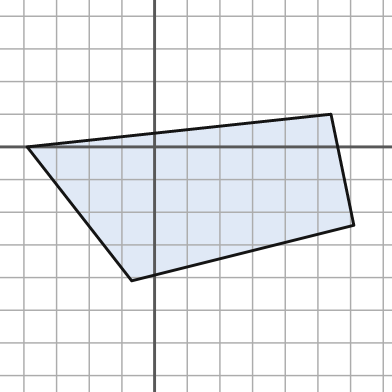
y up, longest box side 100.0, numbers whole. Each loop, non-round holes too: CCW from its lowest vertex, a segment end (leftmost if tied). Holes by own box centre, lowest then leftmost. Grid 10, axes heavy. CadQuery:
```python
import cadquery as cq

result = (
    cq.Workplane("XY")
    .moveTo(-7.0, -41.0)
    .lineTo(61.0, -24.0)
    .lineTo(54.0, 10.0)
    .lineTo(-39.0, 0.0)
    .close()
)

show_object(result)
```